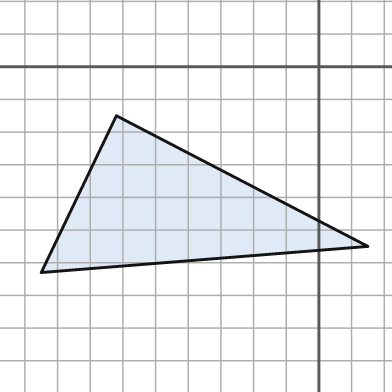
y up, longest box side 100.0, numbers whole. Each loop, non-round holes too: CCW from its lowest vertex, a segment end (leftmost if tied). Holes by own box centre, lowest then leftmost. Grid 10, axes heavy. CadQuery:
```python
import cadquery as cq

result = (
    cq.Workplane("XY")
    .moveTo(-85.0, -63.0)
    .lineTo(15.0, -55.0)
    .lineTo(-62.0, -15.0)
    .close()
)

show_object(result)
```